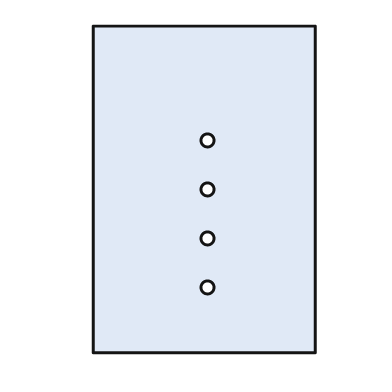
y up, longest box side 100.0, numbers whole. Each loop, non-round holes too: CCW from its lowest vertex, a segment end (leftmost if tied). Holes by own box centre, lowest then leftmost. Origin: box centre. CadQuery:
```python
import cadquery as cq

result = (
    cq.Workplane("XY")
    .moveTo(-34.0, -50.0)
    .lineTo(34.0, -50.0)
    .lineTo(34.0, 50.0)
    .lineTo(-34.0, 50.0)
    .close()
    .moveTo(1.0, -30.0)
    .circle(2.0)
    .moveTo(1.0, -15.0)
    .circle(2.0)
    .moveTo(1.0, 0.0)
    .circle(2.0)
    .moveTo(1.0, 15.0)
    .circle(2.0)
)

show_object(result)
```